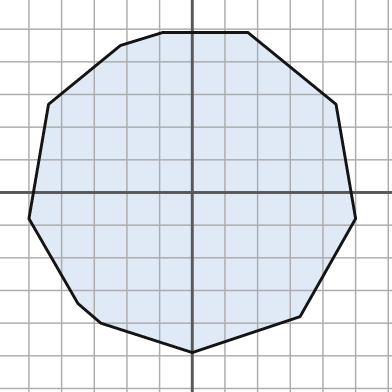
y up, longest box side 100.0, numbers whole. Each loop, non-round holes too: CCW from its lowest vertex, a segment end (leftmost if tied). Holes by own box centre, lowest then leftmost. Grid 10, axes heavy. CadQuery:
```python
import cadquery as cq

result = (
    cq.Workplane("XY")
    .moveTo(0.0, -49.0)
    .lineTo(33.0, -38.0)
    .lineTo(50.0, -8.0)
    .lineTo(44.0, 27.0)
    .lineTo(17.0, 49.0)
    .lineTo(-9.0, 49.0)
    .lineTo(-22.0, 45.0)
    .lineTo(-44.0, 27.0)
    .lineTo(-50.0, -8.0)
    .lineTo(-35.0, -34.0)
    .lineTo(-28.0, -40.0)
    .close()
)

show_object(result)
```